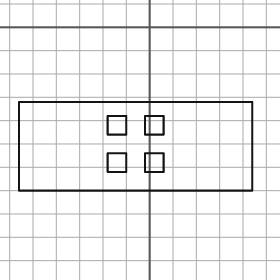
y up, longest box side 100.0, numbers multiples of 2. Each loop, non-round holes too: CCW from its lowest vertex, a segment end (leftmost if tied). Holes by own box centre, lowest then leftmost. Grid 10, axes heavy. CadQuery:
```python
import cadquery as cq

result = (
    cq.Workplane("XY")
    .moveTo(-56.0, -70.0)
    .lineTo(44.0, -70.0)
    .lineTo(44.0, -32.0)
    .lineTo(-56.0, -32.0)
    .close()
    .moveTo(-18.0, -62.0)
    .lineTo(-10.0, -62.0)
    .lineTo(-10.0, -54.0)
    .lineTo(-18.0, -54.0)
    .close()
    .moveTo(-2.0, -62.0)
    .lineTo(6.0, -62.0)
    .lineTo(6.0, -54.0)
    .lineTo(-2.0, -54.0)
    .close()
    .moveTo(-18.0, -46.0)
    .lineTo(-10.0, -46.0)
    .lineTo(-10.0, -38.0)
    .lineTo(-18.0, -38.0)
    .close()
    .moveTo(-2.0, -46.0)
    .lineTo(6.0, -46.0)
    .lineTo(6.0, -38.0)
    .lineTo(-2.0, -38.0)
    .close()
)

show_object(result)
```